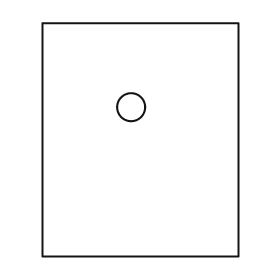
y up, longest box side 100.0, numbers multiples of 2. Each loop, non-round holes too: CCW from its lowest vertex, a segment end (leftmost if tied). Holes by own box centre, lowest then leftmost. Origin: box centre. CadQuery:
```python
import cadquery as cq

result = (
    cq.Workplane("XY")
    .moveTo(-42.0, -50.0)
    .lineTo(42.0, -50.0)
    .lineTo(42.0, 50.0)
    .lineTo(-42.0, 50.0)
    .close()
    .moveTo(-4.0, 14.0)
    .circle(6.0)
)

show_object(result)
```